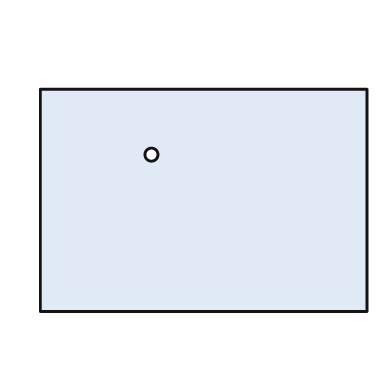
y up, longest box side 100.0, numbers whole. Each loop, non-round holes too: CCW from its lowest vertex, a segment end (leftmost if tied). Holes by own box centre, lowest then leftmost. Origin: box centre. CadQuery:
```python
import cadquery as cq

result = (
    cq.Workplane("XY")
    .moveTo(-50.0, -34.0)
    .lineTo(50.0, -34.0)
    .lineTo(50.0, 34.0)
    .lineTo(-50.0, 34.0)
    .close()
    .moveTo(-16.0, 14.0)
    .circle(2.0)
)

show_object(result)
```